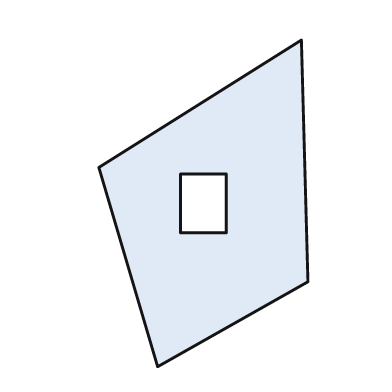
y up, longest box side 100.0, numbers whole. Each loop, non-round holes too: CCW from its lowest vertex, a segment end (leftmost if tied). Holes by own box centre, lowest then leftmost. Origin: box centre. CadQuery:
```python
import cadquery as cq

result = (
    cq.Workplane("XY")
    .moveTo(-14.0, -50.0)
    .lineTo(32.0, -24.0)
    .lineTo(30.0, 50.0)
    .lineTo(-32.0, 11.0)
    .close()
    .moveTo(-7.0, -9.0)
    .lineTo(7.0, -9.0)
    .lineTo(7.0, 9.0)
    .lineTo(-7.0, 9.0)
    .close()
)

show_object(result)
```